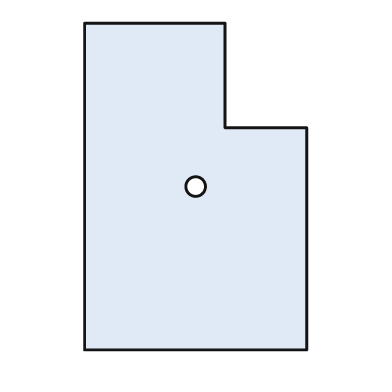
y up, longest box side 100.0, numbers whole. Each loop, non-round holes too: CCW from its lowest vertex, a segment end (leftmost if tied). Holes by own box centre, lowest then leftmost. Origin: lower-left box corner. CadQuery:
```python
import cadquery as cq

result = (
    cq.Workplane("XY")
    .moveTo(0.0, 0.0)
    .lineTo(68.0, 0.0)
    .lineTo(68.0, 68.0)
    .lineTo(43.0, 68.0)
    .lineTo(43.0, 100.0)
    .lineTo(0.0, 100.0)
    .close()
    .moveTo(34.0, 50.0)
    .circle(3.0)
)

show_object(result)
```